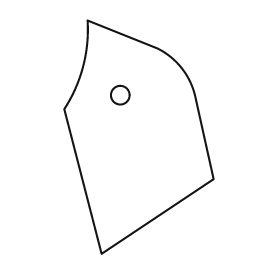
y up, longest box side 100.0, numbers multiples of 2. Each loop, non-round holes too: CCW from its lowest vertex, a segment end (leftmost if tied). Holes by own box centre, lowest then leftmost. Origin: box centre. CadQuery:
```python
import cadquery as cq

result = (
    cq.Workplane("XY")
    .moveTo(-16.0, -50.0)
    .lineTo(32.0, -18.0)
    .lineTo(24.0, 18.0)
    .threePointArc((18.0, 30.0), (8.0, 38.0))
    .lineTo(-22.0, 50.0)
    .threePointArc((-24.0, 30.0), (-32.0, 12.0))
    .close()
    .moveTo(-8.0, 18.0)
    .circle(4.0)
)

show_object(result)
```